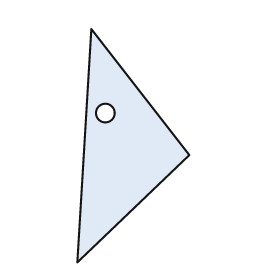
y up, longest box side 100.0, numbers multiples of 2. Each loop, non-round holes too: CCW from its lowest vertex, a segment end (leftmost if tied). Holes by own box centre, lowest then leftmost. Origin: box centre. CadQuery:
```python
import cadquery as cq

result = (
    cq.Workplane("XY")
    .moveTo(-24.0, -50.0)
    .lineTo(24.0, -4.0)
    .lineTo(-18.0, 50.0)
    .close()
    .moveTo(-12.0, 14.0)
    .circle(4.0)
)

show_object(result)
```